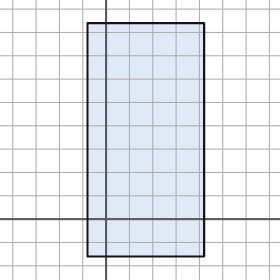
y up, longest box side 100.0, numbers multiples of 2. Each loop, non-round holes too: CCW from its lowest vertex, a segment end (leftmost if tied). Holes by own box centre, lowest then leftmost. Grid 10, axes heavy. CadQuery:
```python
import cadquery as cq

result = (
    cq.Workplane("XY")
    .moveTo(-8.0, -16.0)
    .lineTo(42.0, -16.0)
    .lineTo(42.0, 84.0)
    .lineTo(-8.0, 84.0)
    .close()
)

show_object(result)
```